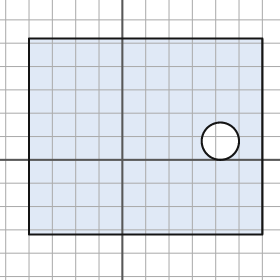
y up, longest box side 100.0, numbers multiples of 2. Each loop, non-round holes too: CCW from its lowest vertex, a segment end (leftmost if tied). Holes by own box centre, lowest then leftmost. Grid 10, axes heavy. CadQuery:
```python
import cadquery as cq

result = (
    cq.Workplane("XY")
    .moveTo(-40.0, -32.0)
    .lineTo(60.0, -32.0)
    .lineTo(60.0, 52.0)
    .lineTo(-40.0, 52.0)
    .close()
    .moveTo(42.0, 8.0)
    .circle(8.0)
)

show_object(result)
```